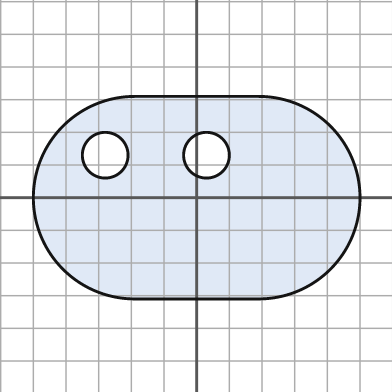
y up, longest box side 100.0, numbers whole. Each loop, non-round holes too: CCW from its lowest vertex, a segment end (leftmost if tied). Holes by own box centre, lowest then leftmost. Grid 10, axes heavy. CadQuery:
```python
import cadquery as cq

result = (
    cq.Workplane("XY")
    .moveTo(-19.0, -31.0)
    .lineTo(19.0, -31.0)
    .threePointArc((50.0, 0.0), (19.0, 31.0))
    .lineTo(-19.0, 31.0)
    .threePointArc((-50.0, 0.0), (-19.0, -31.0))
    .close()
    .moveTo(-28.0, 13.0)
    .circle(7.0)
    .moveTo(3.0, 13.0)
    .circle(7.0)
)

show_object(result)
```